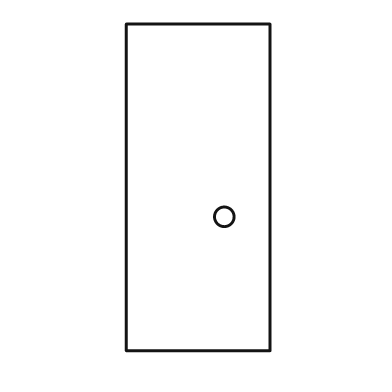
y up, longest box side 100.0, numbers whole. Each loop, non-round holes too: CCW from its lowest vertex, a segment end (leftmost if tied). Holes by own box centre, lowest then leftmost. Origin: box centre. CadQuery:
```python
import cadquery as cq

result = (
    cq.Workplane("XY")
    .moveTo(-22.0, -50.0)
    .lineTo(22.0, -50.0)
    .lineTo(22.0, 50.0)
    .lineTo(-22.0, 50.0)
    .close()
    .moveTo(8.0, -9.0)
    .circle(3.0)
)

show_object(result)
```